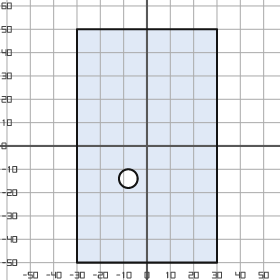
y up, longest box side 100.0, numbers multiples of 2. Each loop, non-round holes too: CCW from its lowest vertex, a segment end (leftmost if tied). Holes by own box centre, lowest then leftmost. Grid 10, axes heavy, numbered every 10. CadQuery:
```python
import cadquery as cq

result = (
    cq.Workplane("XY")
    .moveTo(-30.0, -50.0)
    .lineTo(30.0, -50.0)
    .lineTo(30.0, 50.0)
    .lineTo(-30.0, 50.0)
    .close()
    .moveTo(-8.0, -14.0)
    .circle(4.0)
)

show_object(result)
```